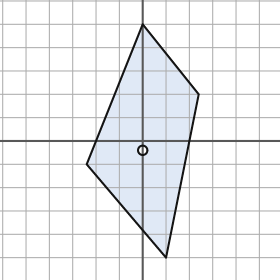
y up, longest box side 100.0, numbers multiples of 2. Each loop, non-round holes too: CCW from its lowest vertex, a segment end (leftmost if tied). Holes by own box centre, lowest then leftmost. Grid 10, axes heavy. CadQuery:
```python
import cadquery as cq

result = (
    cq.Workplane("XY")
    .moveTo(10.0, -50.0)
    .lineTo(24.0, 20.0)
    .lineTo(0.0, 50.0)
    .lineTo(-24.0, -10.0)
    .close()
    .moveTo(0.0, -4.0)
    .circle(2.0)
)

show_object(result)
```